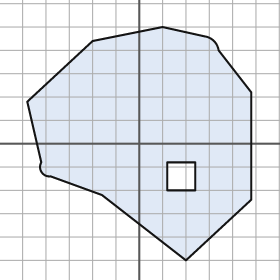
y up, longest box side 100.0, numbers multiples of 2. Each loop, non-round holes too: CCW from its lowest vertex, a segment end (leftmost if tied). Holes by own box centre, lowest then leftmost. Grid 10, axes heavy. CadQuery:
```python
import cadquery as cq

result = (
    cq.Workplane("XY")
    .moveTo(20.0, -50.0)
    .lineTo(48.0, -24.0)
    .lineTo(48.0, 22.0)
    .lineTo(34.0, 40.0)
    .threePointArc((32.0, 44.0), (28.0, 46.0))
    .lineTo(10.0, 50.0)
    .lineTo(-20.0, 44.0)
    .lineTo(-48.0, 18.0)
    .lineTo(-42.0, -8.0)
    .threePointArc((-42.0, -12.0), (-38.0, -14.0))
    .lineTo(-16.0, -22.0)
    .close()
    .moveTo(12.0, -20.0)
    .lineTo(24.0, -20.0)
    .lineTo(24.0, -8.0)
    .lineTo(12.0, -8.0)
    .close()
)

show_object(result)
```